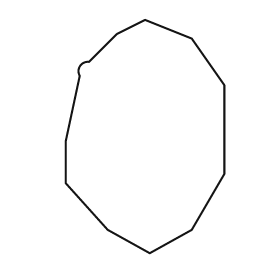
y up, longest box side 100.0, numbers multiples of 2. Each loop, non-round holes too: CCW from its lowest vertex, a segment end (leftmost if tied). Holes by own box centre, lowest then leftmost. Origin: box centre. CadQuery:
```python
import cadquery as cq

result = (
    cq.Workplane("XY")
    .moveTo(2.0, -50.0)
    .lineTo(20.0, -40.0)
    .lineTo(34.0, -16.0)
    .lineTo(34.0, 22.0)
    .lineTo(20.0, 42.0)
    .lineTo(0.0, 50.0)
    .lineTo(-12.0, 44.0)
    .lineTo(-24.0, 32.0)
    .threePointArc((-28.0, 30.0), (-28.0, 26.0))
    .lineTo(-34.0, -2.0)
    .lineTo(-34.0, -20.0)
    .lineTo(-16.0, -40.0)
    .close()
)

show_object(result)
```